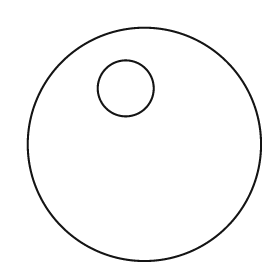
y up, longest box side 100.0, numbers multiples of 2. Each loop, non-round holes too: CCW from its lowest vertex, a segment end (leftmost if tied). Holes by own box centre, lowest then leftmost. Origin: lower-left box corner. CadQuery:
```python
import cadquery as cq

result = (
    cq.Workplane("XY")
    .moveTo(50.0, 50.0)
    .circle(50.0)
    .moveTo(42.0, 74.0)
    .circle(12.0)
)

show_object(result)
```